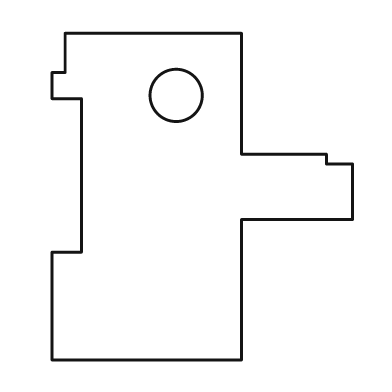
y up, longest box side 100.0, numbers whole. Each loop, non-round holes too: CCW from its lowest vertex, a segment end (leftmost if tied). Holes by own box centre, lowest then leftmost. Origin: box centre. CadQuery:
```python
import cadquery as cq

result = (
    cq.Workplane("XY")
    .moveTo(-46.0, -50.0)
    .lineTo(12.0, -50.0)
    .lineTo(12.0, -7.0)
    .lineTo(46.0, -7.0)
    .lineTo(46.0, 10.0)
    .lineTo(38.0, 10.0)
    .lineTo(38.0, 13.0)
    .lineTo(12.0, 13.0)
    .lineTo(12.0, 50.0)
    .lineTo(-42.0, 50.0)
    .lineTo(-42.0, 38.0)
    .lineTo(-46.0, 38.0)
    .lineTo(-46.0, 30.0)
    .lineTo(-37.0, 30.0)
    .lineTo(-37.0, -17.0)
    .lineTo(-46.0, -17.0)
    .close()
    .moveTo(-8.0, 31.0)
    .circle(8.0)
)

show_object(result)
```